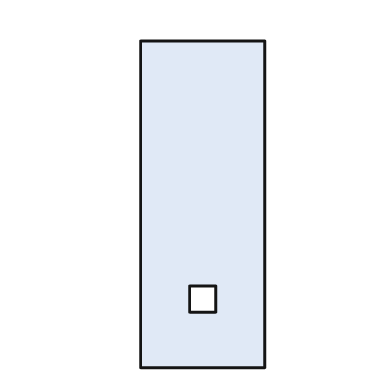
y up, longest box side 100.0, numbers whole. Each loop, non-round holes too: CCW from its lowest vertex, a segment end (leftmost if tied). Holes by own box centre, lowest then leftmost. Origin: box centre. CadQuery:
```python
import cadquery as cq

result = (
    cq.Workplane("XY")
    .moveTo(-19.0, -50.0)
    .lineTo(19.0, -50.0)
    .lineTo(19.0, 50.0)
    .lineTo(-19.0, 50.0)
    .close()
    .moveTo(-4.0, -33.0)
    .lineTo(4.0, -33.0)
    .lineTo(4.0, -25.0)
    .lineTo(-4.0, -25.0)
    .close()
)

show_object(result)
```